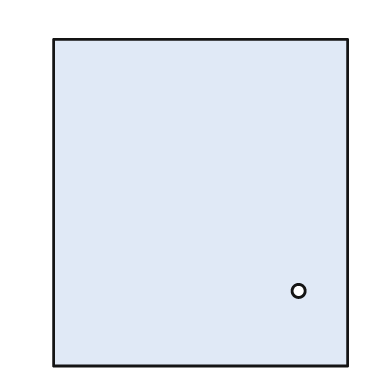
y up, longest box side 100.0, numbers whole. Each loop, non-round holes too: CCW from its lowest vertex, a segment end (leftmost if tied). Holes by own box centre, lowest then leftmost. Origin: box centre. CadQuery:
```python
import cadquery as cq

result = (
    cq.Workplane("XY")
    .moveTo(-45.0, -50.0)
    .lineTo(45.0, -50.0)
    .lineTo(45.0, 50.0)
    .lineTo(-45.0, 50.0)
    .close()
    .moveTo(30.0, -27.0)
    .circle(2.0)
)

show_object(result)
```